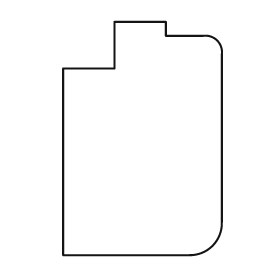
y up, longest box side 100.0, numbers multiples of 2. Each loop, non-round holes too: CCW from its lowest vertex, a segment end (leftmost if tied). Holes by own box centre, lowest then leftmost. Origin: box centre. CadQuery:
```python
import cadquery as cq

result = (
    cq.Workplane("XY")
    .moveTo(-34.0, -50.0)
    .lineTo(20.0, -50.0)
    .threePointArc((30.0, -46.0), (34.0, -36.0))
    .lineTo(34.0, 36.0)
    .threePointArc((32.0, 42.0), (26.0, 44.0))
    .lineTo(10.0, 44.0)
    .lineTo(10.0, 50.0)
    .lineTo(-12.0, 50.0)
    .lineTo(-12.0, 30.0)
    .lineTo(-34.0, 30.0)
    .close()
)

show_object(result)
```